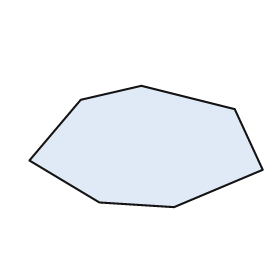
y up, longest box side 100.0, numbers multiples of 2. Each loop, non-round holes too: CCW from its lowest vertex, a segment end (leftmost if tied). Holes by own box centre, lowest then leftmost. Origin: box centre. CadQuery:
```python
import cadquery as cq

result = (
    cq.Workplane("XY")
    .moveTo(12.0, -26.0)
    .lineTo(50.0, -10.0)
    .lineTo(38.0, 16.0)
    .lineTo(-2.0, 26.0)
    .lineTo(-28.0, 20.0)
    .lineTo(-50.0, -6.0)
    .lineTo(-20.0, -24.0)
    .close()
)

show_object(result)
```